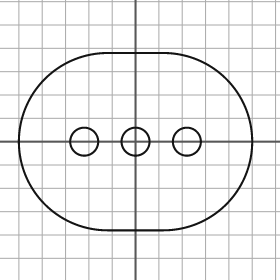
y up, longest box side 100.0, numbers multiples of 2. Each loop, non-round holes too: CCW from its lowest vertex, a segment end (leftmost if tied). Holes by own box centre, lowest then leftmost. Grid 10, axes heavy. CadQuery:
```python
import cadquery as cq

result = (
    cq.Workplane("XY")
    .moveTo(-12.0, -38.0)
    .lineTo(12.0, -38.0)
    .threePointArc((50.0, 0.0), (12.0, 38.0))
    .lineTo(-12.0, 38.0)
    .threePointArc((-50.0, 0.0), (-12.0, -38.0))
    .close()
    .moveTo(-22.0, 0.0)
    .circle(6.0)
    .moveTo(0.0, 0.0)
    .circle(6.0)
    .moveTo(22.0, 0.0)
    .circle(6.0)
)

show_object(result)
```